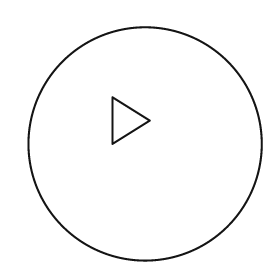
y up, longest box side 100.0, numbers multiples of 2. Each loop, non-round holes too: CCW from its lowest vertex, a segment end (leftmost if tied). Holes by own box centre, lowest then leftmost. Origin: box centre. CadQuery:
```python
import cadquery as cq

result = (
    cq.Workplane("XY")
    .moveTo(0.0, 0.0)
    .circle(50.0)
    .moveTo(-14.0, 0.0)
    .lineTo(2.0, 10.0)
    .lineTo(-14.0, 20.0)
    .close()
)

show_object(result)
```